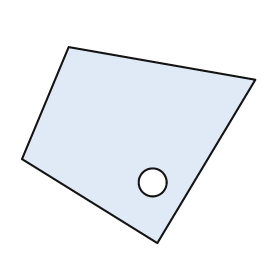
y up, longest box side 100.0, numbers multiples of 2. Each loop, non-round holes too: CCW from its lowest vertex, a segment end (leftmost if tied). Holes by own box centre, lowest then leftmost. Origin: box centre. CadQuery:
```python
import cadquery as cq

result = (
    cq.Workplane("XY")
    .moveTo(8.0, -42.0)
    .lineTo(50.0, 28.0)
    .lineTo(-30.0, 42.0)
    .lineTo(-50.0, -6.0)
    .close()
    .moveTo(6.0, -16.0)
    .circle(6.0)
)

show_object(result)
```